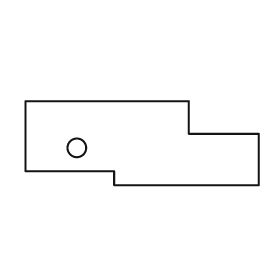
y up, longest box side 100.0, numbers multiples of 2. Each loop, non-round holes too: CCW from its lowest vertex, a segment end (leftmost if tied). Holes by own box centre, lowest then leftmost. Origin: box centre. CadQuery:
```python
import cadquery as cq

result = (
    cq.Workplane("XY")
    .moveTo(-12.0, -18.0)
    .lineTo(50.0, -18.0)
    .lineTo(50.0, 4.0)
    .lineTo(20.0, 4.0)
    .lineTo(20.0, 18.0)
    .lineTo(-50.0, 18.0)
    .lineTo(-50.0, -12.0)
    .lineTo(-12.0, -12.0)
    .close()
    .moveTo(-28.0, -2.0)
    .circle(4.0)
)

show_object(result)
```